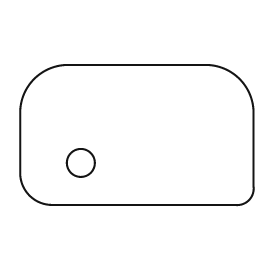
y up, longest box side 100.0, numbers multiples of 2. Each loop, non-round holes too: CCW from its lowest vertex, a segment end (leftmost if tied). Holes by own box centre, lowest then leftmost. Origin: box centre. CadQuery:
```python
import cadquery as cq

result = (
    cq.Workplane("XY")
    .moveTo(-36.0, -30.0)
    .lineTo(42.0, -30.0)
    .threePointArc((48.0, -28.0), (50.0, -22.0))
    .lineTo(50.0, 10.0)
    .threePointArc((44.0, 24.0), (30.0, 30.0))
    .lineTo(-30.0, 30.0)
    .threePointArc((-44.0, 24.0), (-50.0, 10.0))
    .lineTo(-50.0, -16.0)
    .threePointArc((-46.0, -26.0), (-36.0, -30.0))
    .close()
    .moveTo(-24.0, -12.0)
    .circle(6.0)
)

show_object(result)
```